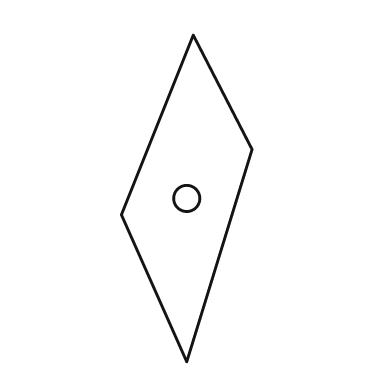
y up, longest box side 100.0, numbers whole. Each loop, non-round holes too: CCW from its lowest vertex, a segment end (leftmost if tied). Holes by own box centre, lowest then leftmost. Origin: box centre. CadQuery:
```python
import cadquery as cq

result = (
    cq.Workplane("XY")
    .moveTo(0.0, -50.0)
    .lineTo(20.0, 15.0)
    .lineTo(2.0, 50.0)
    .lineTo(-20.0, -5.0)
    .close()
    .moveTo(0.0, 0.0)
    .circle(4.0)
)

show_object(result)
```